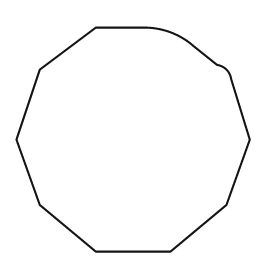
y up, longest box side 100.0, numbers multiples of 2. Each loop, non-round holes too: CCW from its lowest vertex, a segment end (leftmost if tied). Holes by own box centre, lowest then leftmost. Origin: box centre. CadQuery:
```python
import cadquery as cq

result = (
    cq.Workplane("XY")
    .moveTo(-16.0, -48.0)
    .lineTo(16.0, -48.0)
    .lineTo(40.0, -28.0)
    .lineTo(50.0, 0.0)
    .lineTo(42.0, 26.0)
    .threePointArc((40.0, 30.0), (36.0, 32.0))
    .lineTo(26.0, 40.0)
    .threePointArc((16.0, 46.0), (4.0, 48.0))
    .lineTo(-16.0, 48.0)
    .lineTo(-40.0, 30.0)
    .lineTo(-50.0, 0.0)
    .lineTo(-40.0, -28.0)
    .close()
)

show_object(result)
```